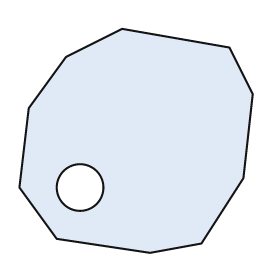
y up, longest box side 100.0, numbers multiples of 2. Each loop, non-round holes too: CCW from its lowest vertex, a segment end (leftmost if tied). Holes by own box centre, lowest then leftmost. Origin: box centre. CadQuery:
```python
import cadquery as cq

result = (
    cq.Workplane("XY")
    .moveTo(6.0, -48.0)
    .lineTo(28.0, -44.0)
    .lineTo(46.0, -16.0)
    .lineTo(50.0, 20.0)
    .lineTo(40.0, 40.0)
    .lineTo(-6.0, 48.0)
    .lineTo(-30.0, 36.0)
    .lineTo(-46.0, 14.0)
    .lineTo(-50.0, -20.0)
    .lineTo(-34.0, -42.0)
    .close()
    .moveTo(-24.0, -20.0)
    .circle(10.0)
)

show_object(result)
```